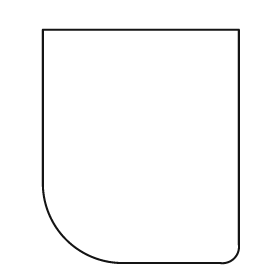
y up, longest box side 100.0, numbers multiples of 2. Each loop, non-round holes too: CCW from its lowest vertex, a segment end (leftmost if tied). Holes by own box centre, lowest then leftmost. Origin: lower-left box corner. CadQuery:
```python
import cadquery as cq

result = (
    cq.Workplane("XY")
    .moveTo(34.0, 0.0)
    .lineTo(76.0, 0.0)
    .threePointArc((82.0, 2.0), (84.0, 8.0))
    .lineTo(84.0, 100.0)
    .lineTo(0.0, 100.0)
    .lineTo(0.0, 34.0)
    .threePointArc((10.0, 10.0), (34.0, 0.0))
    .close()
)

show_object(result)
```